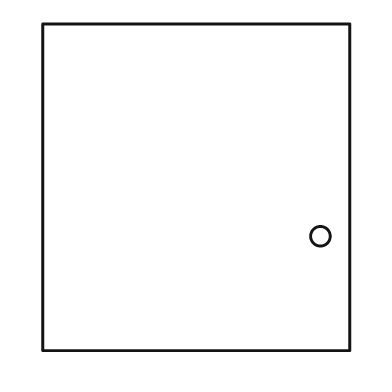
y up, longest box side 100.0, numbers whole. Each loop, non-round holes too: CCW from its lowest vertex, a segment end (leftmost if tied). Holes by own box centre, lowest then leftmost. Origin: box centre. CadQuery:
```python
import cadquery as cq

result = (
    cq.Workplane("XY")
    .moveTo(-47.0, -50.0)
    .lineTo(47.0, -50.0)
    .lineTo(47.0, 50.0)
    .lineTo(-47.0, 50.0)
    .close()
    .moveTo(38.0, -15.0)
    .circle(3.0)
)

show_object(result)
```